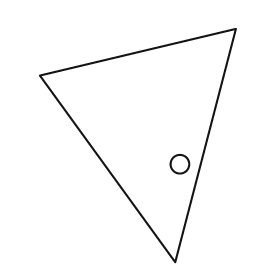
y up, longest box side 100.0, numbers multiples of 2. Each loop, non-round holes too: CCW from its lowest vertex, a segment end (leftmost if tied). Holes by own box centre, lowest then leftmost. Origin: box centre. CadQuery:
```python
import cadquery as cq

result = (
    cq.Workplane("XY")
    .moveTo(16.0, -50.0)
    .lineTo(42.0, 50.0)
    .lineTo(-42.0, 30.0)
    .close()
    .moveTo(18.0, -8.0)
    .circle(4.0)
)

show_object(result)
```